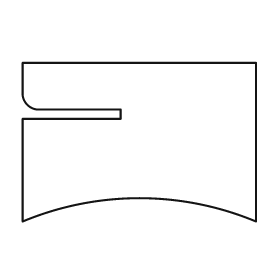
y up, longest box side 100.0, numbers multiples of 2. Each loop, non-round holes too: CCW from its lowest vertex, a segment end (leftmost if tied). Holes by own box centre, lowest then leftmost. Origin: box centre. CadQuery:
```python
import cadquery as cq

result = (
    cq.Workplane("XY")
    .moveTo(-50.0, -34.0)
    .threePointArc((0.0, -24.0), (50.0, -34.0))
    .lineTo(50.0, 34.0)
    .lineTo(-50.0, 34.0)
    .lineTo(-50.0, 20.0)
    .threePointArc((-48.0, 16.0), (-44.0, 14.0))
    .lineTo(-8.0, 14.0)
    .lineTo(-8.0, 10.0)
    .lineTo(-50.0, 10.0)
    .close()
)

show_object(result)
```